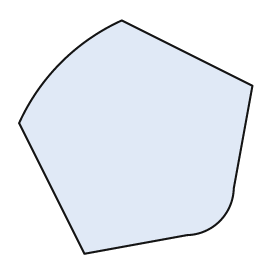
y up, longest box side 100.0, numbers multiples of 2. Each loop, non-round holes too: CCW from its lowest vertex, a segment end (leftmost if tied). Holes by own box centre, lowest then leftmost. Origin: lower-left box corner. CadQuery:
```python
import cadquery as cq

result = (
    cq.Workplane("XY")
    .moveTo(28.0, 0.0)
    .lineTo(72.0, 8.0)
    .threePointArc((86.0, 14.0), (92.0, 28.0))
    .lineTo(100.0, 72.0)
    .lineTo(44.0, 100.0)
    .threePointArc((18.0, 82.0), (0.0, 56.0))
    .close()
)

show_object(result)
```